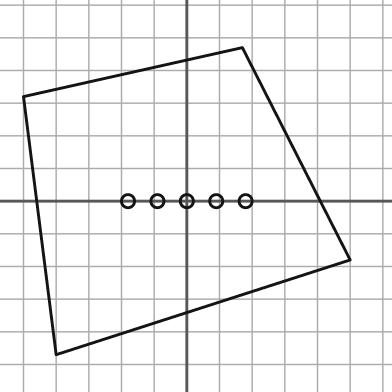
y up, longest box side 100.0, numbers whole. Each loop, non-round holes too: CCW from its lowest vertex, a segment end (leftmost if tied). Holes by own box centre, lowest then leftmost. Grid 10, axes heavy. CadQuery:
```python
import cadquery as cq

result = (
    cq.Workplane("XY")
    .moveTo(-40.0, -47.0)
    .lineTo(50.0, -18.0)
    .lineTo(17.0, 47.0)
    .lineTo(-50.0, 32.0)
    .close()
    .moveTo(-18.0, 0.0)
    .circle(2.0)
    .moveTo(-9.0, 0.0)
    .circle(2.0)
    .moveTo(0.0, 0.0)
    .circle(2.0)
    .moveTo(9.0, 0.0)
    .circle(2.0)
    .moveTo(18.0, 0.0)
    .circle(2.0)
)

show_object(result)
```